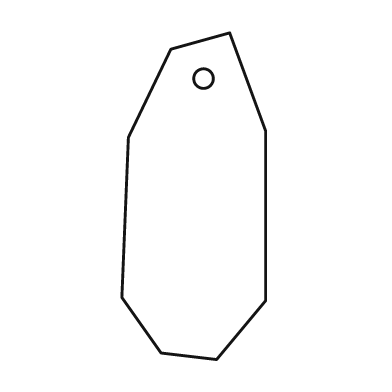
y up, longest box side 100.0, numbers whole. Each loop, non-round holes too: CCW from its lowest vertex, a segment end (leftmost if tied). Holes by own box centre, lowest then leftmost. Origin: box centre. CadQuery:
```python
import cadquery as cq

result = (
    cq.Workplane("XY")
    .moveTo(7.0, -50.0)
    .lineTo(22.0, -32.0)
    .lineTo(22.0, 20.0)
    .lineTo(11.0, 50.0)
    .lineTo(-7.0, 45.0)
    .lineTo(-20.0, 18.0)
    .lineTo(-22.0, -31.0)
    .lineTo(-10.0, -48.0)
    .close()
    .moveTo(3.0, 36.0)
    .circle(3.0)
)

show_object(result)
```